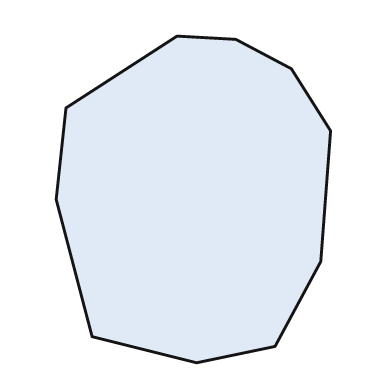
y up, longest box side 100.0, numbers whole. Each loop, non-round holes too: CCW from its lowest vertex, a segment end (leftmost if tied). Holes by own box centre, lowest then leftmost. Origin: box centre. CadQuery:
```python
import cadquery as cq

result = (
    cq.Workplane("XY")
    .moveTo(1.0, -50.0)
    .lineTo(25.0, -45.0)
    .lineTo(39.0, -19.0)
    .lineTo(42.0, 21.0)
    .lineTo(30.0, 40.0)
    .lineTo(13.0, 49.0)
    .lineTo(-5.0, 50.0)
    .lineTo(-39.0, 28.0)
    .lineTo(-42.0, 0.0)
    .lineTo(-31.0, -42.0)
    .close()
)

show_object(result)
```